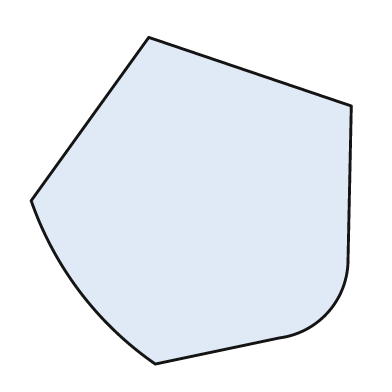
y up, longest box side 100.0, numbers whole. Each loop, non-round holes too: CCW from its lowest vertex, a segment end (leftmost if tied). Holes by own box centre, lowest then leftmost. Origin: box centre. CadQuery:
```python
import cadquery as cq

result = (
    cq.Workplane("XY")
    .moveTo(-11.0, -50.0)
    .lineTo(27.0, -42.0)
    .threePointArc((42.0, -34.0), (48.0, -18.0))
    .lineTo(49.0, 29.0)
    .lineTo(-13.0, 50.0)
    .lineTo(-49.0, 0.0)
    .threePointArc((-34.0, -28.0), (-11.0, -50.0))
    .close()
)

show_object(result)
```